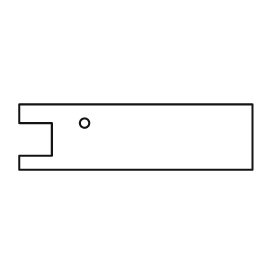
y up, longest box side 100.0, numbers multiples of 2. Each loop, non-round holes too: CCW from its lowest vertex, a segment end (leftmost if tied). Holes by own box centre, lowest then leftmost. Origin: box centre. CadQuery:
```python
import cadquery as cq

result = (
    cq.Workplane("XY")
    .moveTo(-50.0, -14.0)
    .lineTo(50.0, -14.0)
    .lineTo(50.0, 14.0)
    .lineTo(-50.0, 14.0)
    .lineTo(-50.0, 6.0)
    .lineTo(-36.0, 6.0)
    .lineTo(-36.0, -8.0)
    .lineTo(-50.0, -8.0)
    .close()
    .moveTo(-22.0, 6.0)
    .circle(2.0)
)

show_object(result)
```